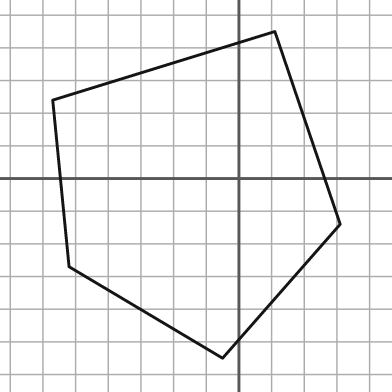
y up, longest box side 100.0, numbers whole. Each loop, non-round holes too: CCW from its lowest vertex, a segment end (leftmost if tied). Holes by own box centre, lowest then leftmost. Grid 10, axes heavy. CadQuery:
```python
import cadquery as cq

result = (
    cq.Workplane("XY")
    .moveTo(-5.0, -55.0)
    .lineTo(31.0, -14.0)
    .lineTo(11.0, 45.0)
    .lineTo(-57.0, 24.0)
    .lineTo(-52.0, -27.0)
    .close()
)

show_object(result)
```